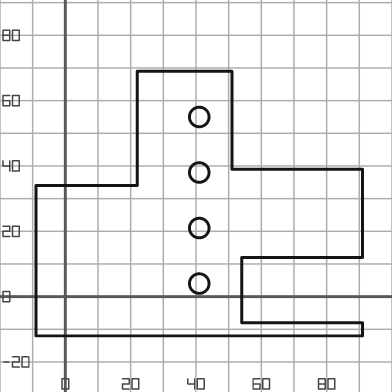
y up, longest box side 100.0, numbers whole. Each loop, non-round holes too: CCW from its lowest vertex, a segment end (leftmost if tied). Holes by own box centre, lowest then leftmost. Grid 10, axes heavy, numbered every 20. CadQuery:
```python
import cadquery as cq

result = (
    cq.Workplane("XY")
    .moveTo(-9.0, -12.0)
    .lineTo(91.0, -12.0)
    .lineTo(91.0, -8.0)
    .lineTo(54.0, -8.0)
    .lineTo(54.0, 12.0)
    .lineTo(91.0, 12.0)
    .lineTo(91.0, 39.0)
    .lineTo(51.0, 39.0)
    .lineTo(51.0, 69.0)
    .lineTo(22.0, 69.0)
    .lineTo(22.0, 34.0)
    .lineTo(-9.0, 34.0)
    .close()
    .moveTo(41.0, 4.0)
    .circle(3.0)
    .moveTo(41.0, 21.0)
    .circle(3.0)
    .moveTo(41.0, 38.0)
    .circle(3.0)
    .moveTo(41.0, 55.0)
    .circle(3.0)
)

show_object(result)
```